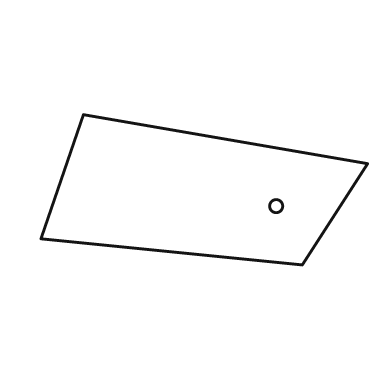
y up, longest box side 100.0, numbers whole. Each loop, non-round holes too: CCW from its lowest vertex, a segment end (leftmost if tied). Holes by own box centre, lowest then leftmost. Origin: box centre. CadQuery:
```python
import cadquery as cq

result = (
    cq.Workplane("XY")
    .moveTo(30.0, -23.0)
    .lineTo(50.0, 8.0)
    .lineTo(-37.0, 23.0)
    .lineTo(-50.0, -15.0)
    .close()
    .moveTo(22.0, -5.0)
    .circle(2.0)
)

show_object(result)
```